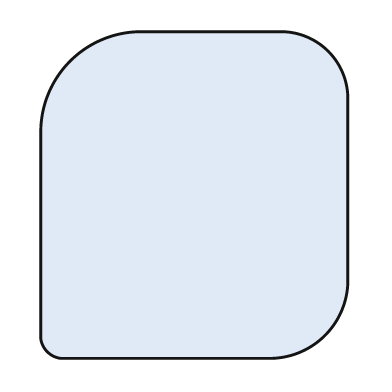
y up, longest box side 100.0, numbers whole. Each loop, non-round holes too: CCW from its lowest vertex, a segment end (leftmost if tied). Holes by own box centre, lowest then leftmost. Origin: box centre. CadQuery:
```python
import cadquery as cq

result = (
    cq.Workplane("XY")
    .moveTo(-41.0, -50.0)
    .lineTo(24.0, -50.0)
    .threePointArc((40.0, -43.0), (47.0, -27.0))
    .lineTo(47.0, 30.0)
    .threePointArc((41.0, 44.0), (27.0, 50.0))
    .lineTo(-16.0, 50.0)
    .threePointArc((-38.0, 41.0), (-47.0, 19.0))
    .lineTo(-47.0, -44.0)
    .threePointArc((-45.0, -48.0), (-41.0, -50.0))
    .close()
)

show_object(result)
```